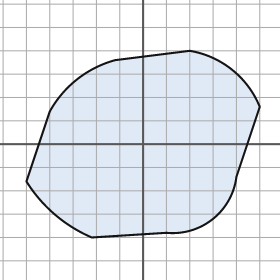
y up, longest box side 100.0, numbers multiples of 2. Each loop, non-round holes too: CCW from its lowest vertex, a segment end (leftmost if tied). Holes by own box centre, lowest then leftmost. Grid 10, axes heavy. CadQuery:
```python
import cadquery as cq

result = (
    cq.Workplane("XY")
    .moveTo(-22.0, -40.0)
    .lineTo(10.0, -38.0)
    .threePointArc((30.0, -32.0), (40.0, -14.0))
    .lineTo(50.0, 16.0)
    .threePointArc((38.0, 32.0), (20.0, 40.0))
    .lineTo(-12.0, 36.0)
    .threePointArc((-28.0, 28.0), (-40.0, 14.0))
    .lineTo(-50.0, -16.0)
    .threePointArc((-38.0, -30.0), (-22.0, -40.0))
    .close()
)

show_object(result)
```